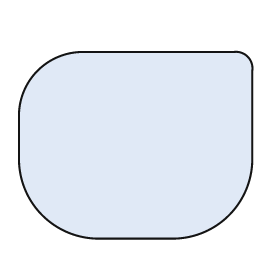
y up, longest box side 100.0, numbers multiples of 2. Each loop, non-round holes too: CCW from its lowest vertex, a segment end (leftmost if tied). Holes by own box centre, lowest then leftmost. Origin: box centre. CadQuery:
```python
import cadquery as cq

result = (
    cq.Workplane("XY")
    .moveTo(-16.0, -40.0)
    .lineTo(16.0, -40.0)
    .threePointArc((40.0, -30.0), (50.0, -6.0))
    .lineTo(50.0, 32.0)
    .threePointArc((48.0, 38.0), (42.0, 40.0))
    .lineTo(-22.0, 40.0)
    .threePointArc((-42.0, 32.0), (-50.0, 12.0))
    .lineTo(-50.0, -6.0)
    .threePointArc((-40.0, -30.0), (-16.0, -40.0))
    .close()
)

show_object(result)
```